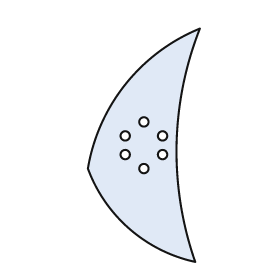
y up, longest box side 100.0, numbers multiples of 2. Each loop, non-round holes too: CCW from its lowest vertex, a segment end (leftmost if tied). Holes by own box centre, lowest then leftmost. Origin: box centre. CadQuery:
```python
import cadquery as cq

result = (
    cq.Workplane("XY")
    .moveTo(22.0, -50.0)
    .threePointArc((14.0, 0.0), (24.0, 50.0))
    .threePointArc((-8.0, 26.0), (-24.0, -10.0))
    .threePointArc((-6.0, -36.0), (22.0, -50.0))
    .close()
    .moveTo(0.0, -10.0)
    .circle(2.0)
    .moveTo(-8.0, -4.0)
    .circle(2.0)
    .moveTo(8.0, -4.0)
    .circle(2.0)
    .moveTo(-8.0, 4.0)
    .circle(2.0)
    .moveTo(8.0, 4.0)
    .circle(2.0)
    .moveTo(0.0, 10.0)
    .circle(2.0)
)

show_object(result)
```